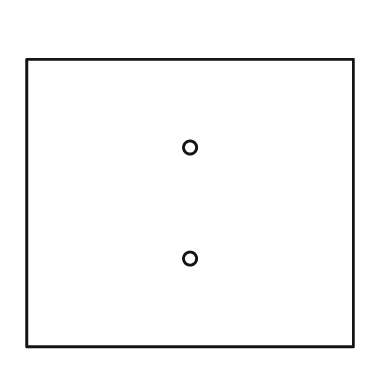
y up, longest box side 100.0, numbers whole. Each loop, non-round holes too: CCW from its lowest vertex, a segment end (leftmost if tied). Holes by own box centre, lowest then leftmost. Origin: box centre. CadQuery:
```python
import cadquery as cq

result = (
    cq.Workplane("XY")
    .moveTo(-50.0, -44.0)
    .lineTo(50.0, -44.0)
    .lineTo(50.0, 44.0)
    .lineTo(-50.0, 44.0)
    .close()
    .moveTo(0.0, -17.0)
    .circle(2.0)
    .moveTo(0.0, 17.0)
    .circle(2.0)
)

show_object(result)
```